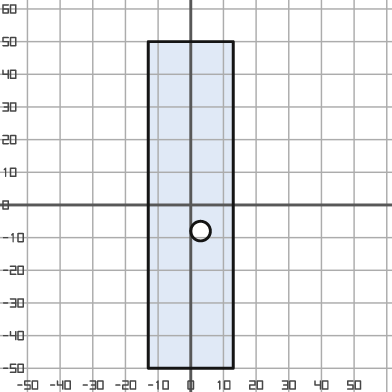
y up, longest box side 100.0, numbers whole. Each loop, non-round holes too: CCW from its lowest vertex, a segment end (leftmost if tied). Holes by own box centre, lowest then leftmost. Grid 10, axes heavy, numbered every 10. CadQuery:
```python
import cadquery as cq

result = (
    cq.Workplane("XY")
    .moveTo(-13.0, -50.0)
    .lineTo(13.0, -50.0)
    .lineTo(13.0, 50.0)
    .lineTo(-13.0, 50.0)
    .close()
    .moveTo(3.0, -8.0)
    .circle(3.0)
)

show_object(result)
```